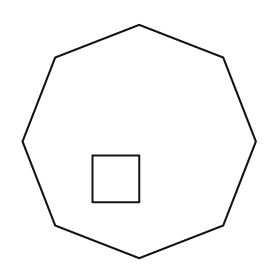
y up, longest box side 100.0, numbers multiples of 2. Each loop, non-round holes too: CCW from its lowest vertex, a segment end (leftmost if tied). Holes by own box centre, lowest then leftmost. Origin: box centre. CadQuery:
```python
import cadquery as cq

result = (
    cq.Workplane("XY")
    .moveTo(0.0, -50.0)
    .lineTo(36.0, -36.0)
    .lineTo(50.0, 0.0)
    .lineTo(36.0, 36.0)
    .lineTo(0.0, 50.0)
    .lineTo(-36.0, 36.0)
    .lineTo(-50.0, 0.0)
    .lineTo(-36.0, -36.0)
    .close()
    .moveTo(-20.0, -26.0)
    .lineTo(0.0, -26.0)
    .lineTo(0.0, -6.0)
    .lineTo(-20.0, -6.0)
    .close()
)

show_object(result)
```